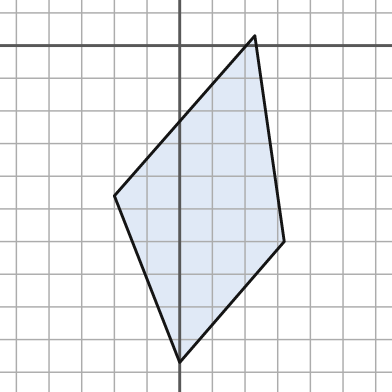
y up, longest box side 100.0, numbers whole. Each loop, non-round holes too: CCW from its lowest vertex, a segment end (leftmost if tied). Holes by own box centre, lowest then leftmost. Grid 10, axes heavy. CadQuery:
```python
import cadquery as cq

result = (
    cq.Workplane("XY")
    .moveTo(0.0, -97.0)
    .lineTo(32.0, -60.0)
    .lineTo(23.0, 3.0)
    .lineTo(-20.0, -46.0)
    .close()
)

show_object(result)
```